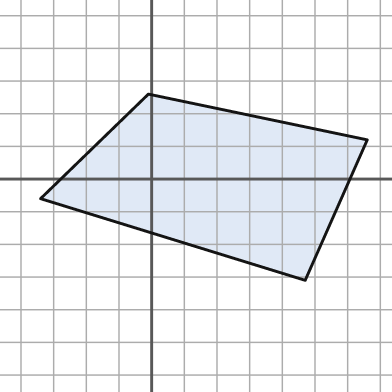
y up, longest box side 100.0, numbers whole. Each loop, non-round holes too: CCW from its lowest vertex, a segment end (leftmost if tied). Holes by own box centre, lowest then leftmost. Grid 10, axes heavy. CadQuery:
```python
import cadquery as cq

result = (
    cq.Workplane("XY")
    .moveTo(47.0, -31.0)
    .lineTo(66.0, 12.0)
    .lineTo(-1.0, 26.0)
    .lineTo(-34.0, -6.0)
    .close()
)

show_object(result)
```